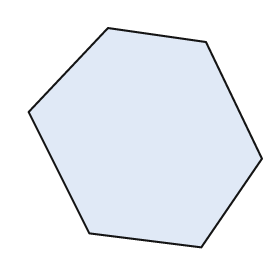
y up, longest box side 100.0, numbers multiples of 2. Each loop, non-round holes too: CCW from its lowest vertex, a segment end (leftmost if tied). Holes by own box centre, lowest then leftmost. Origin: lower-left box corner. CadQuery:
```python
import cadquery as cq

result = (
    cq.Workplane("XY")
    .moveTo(74.0, 0.0)
    .lineTo(100.0, 38.0)
    .lineTo(76.0, 88.0)
    .lineTo(34.0, 94.0)
    .lineTo(0.0, 58.0)
    .lineTo(26.0, 6.0)
    .close()
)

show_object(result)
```